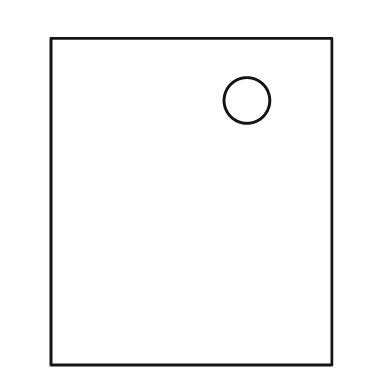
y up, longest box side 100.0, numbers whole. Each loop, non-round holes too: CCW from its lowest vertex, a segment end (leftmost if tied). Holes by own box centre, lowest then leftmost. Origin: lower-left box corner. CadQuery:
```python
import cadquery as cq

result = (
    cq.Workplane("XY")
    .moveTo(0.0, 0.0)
    .lineTo(86.0, 0.0)
    .lineTo(86.0, 100.0)
    .lineTo(0.0, 100.0)
    .close()
    .moveTo(60.0, 81.0)
    .circle(7.0)
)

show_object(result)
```